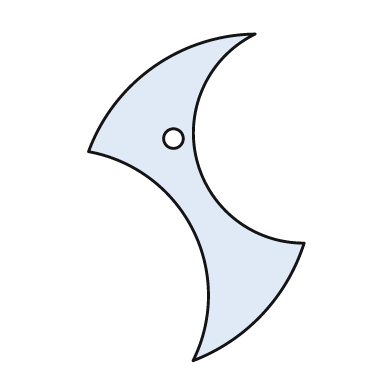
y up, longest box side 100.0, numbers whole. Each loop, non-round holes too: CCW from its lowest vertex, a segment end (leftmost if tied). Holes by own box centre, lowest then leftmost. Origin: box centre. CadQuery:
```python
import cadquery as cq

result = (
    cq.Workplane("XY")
    .moveTo(-1.0, -50.0)
    .threePointArc((20.0, -36.0), (33.0, -14.0))
    .threePointArc((0.0, 12.0), (18.0, 50.0))
    .threePointArc((-13.0, 40.0), (-33.0, 14.0))
    .threePointArc((-1.0, -10.0), (-1.0, -50.0))
    .close()
    .moveTo(-7.0, 18.0)
    .circle(3.0)
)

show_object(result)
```